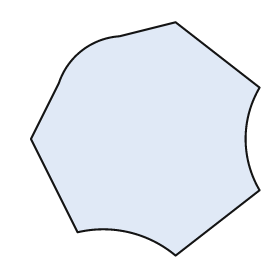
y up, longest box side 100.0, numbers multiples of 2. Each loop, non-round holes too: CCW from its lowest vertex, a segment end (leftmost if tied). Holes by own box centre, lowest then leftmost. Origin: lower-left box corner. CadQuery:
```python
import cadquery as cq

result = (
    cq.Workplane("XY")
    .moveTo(62.0, 0.0)
    .lineTo(98.0, 28.0)
    .threePointArc((92.0, 50.0), (98.0, 72.0))
    .lineTo(62.0, 100.0)
    .lineTo(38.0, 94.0)
    .threePointArc((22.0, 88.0), (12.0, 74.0))
    .lineTo(0.0, 50.0)
    .lineTo(20.0, 10.0)
    .threePointArc((42.0, 10.0), (62.0, 0.0))
    .close()
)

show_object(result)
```